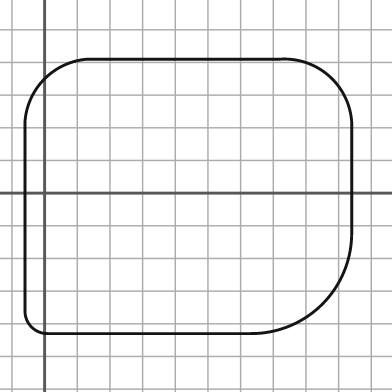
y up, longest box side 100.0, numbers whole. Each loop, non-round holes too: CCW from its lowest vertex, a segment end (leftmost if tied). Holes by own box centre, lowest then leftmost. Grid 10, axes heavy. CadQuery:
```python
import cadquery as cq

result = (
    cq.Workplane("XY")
    .moveTo(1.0, -43.0)
    .lineTo(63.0, -43.0)
    .threePointArc((85.0, -34.0), (94.0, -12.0))
    .lineTo(94.0, 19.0)
    .threePointArc((88.0, 35.0), (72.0, 41.0))
    .lineTo(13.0, 41.0)
    .threePointArc((0.0, 35.0), (-6.0, 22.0))
    .lineTo(-6.0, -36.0)
    .threePointArc((-4.0, -41.0), (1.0, -43.0))
    .close()
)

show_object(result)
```